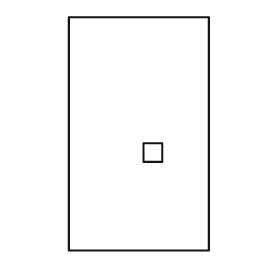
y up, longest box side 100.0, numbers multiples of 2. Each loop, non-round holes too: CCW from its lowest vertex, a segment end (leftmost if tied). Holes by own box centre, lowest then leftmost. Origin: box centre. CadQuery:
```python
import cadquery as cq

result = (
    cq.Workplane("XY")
    .moveTo(-30.0, -50.0)
    .lineTo(30.0, -50.0)
    .lineTo(30.0, 50.0)
    .lineTo(-30.0, 50.0)
    .close()
    .moveTo(2.0, -12.0)
    .lineTo(10.0, -12.0)
    .lineTo(10.0, -4.0)
    .lineTo(2.0, -4.0)
    .close()
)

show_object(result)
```